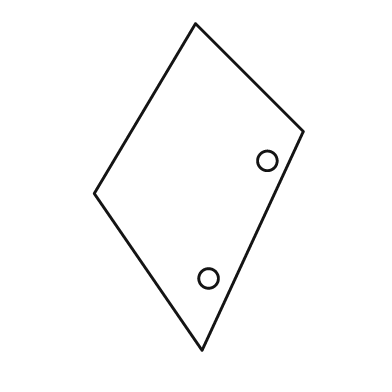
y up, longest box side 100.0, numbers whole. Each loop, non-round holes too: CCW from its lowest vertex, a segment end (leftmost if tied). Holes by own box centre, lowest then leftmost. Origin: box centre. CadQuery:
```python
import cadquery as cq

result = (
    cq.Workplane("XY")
    .moveTo(1.0, -50.0)
    .lineTo(32.0, 17.0)
    .lineTo(-1.0, 50.0)
    .lineTo(-32.0, -2.0)
    .close()
    .moveTo(3.0, -28.0)
    .circle(3.0)
    .moveTo(21.0, 8.0)
    .circle(3.0)
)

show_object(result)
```